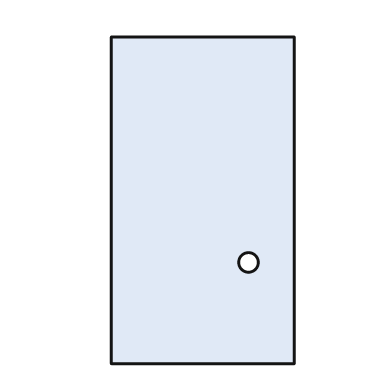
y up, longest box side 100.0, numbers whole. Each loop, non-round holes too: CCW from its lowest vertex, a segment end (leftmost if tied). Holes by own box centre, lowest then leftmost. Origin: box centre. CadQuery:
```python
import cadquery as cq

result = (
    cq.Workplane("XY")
    .moveTo(-28.0, -50.0)
    .lineTo(28.0, -50.0)
    .lineTo(28.0, 50.0)
    .lineTo(-28.0, 50.0)
    .close()
    .moveTo(14.0, -19.0)
    .circle(3.0)
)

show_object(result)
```